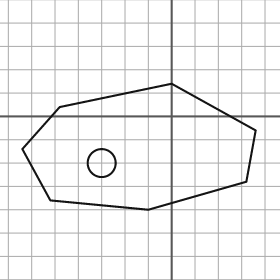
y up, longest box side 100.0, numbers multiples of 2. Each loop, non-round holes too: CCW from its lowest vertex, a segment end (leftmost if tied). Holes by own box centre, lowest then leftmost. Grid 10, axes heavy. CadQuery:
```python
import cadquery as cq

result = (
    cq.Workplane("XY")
    .moveTo(-10.0, -40.0)
    .lineTo(32.0, -28.0)
    .lineTo(36.0, -6.0)
    .lineTo(0.0, 14.0)
    .lineTo(-48.0, 4.0)
    .lineTo(-64.0, -14.0)
    .lineTo(-52.0, -36.0)
    .close()
    .moveTo(-30.0, -20.0)
    .circle(6.0)
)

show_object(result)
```